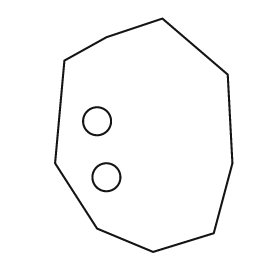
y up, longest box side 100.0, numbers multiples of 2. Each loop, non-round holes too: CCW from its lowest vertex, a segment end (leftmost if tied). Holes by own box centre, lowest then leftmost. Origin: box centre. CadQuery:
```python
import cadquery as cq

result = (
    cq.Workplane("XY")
    .moveTo(4.0, -50.0)
    .lineTo(30.0, -42.0)
    .lineTo(38.0, -12.0)
    .lineTo(36.0, 26.0)
    .lineTo(8.0, 50.0)
    .lineTo(-16.0, 42.0)
    .lineTo(-34.0, 32.0)
    .lineTo(-38.0, -12.0)
    .lineTo(-20.0, -40.0)
    .close()
    .moveTo(-16.0, -18.0)
    .circle(6.0)
    .moveTo(-20.0, 6.0)
    .circle(6.0)
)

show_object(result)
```